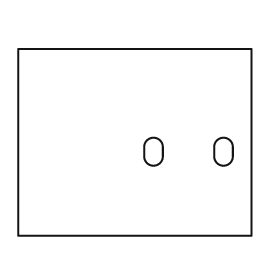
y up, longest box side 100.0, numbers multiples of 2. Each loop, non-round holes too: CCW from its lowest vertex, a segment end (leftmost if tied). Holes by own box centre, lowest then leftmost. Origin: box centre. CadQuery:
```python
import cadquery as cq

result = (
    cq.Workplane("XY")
    .moveTo(-50.0, -40.0)
    .lineTo(50.0, -40.0)
    .lineTo(50.0, 40.0)
    .lineTo(-50.0, 40.0)
    .close()
    .moveTo(4.0, -6.0)
    .threePointArc((8.0, -10.0), (12.0, -6.0))
    .lineTo(12.0, -2.0)
    .threePointArc((8.0, 2.0), (4.0, -2.0))
    .close()
    .moveTo(34.0, -6.0)
    .threePointArc((38.0, -10.0), (42.0, -6.0))
    .lineTo(42.0, -2.0)
    .threePointArc((38.0, 2.0), (34.0, -2.0))
    .close()
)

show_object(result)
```